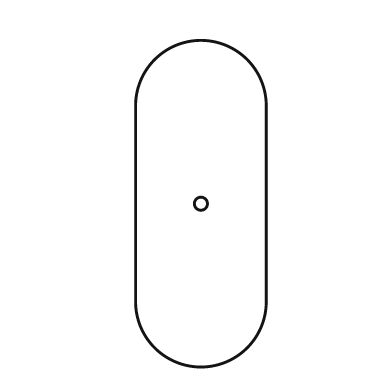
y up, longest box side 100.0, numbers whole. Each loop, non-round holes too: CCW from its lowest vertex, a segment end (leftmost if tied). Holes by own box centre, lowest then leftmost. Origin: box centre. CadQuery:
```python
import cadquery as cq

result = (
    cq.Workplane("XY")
    .moveTo(-20.0, -30.0)
    .threePointArc((0.0, -50.0), (20.0, -30.0))
    .lineTo(20.0, 30.0)
    .threePointArc((0.0, 50.0), (-20.0, 30.0))
    .close()
    .moveTo(0.0, 0.0)
    .circle(2.0)
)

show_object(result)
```